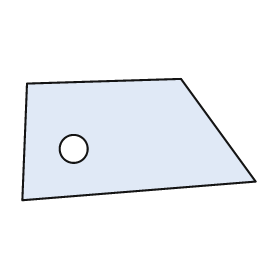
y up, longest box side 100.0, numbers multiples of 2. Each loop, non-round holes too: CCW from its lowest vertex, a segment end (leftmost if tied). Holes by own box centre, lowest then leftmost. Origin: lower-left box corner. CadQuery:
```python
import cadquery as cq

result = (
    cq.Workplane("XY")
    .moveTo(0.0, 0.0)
    .lineTo(100.0, 8.0)
    .lineTo(68.0, 52.0)
    .lineTo(2.0, 50.0)
    .close()
    .moveTo(22.0, 22.0)
    .circle(6.0)
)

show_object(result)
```